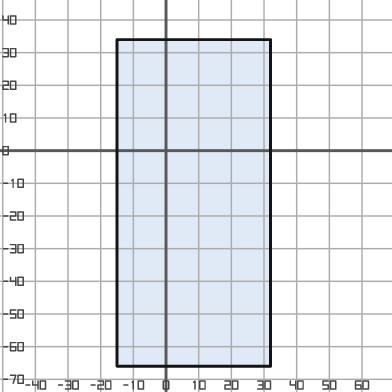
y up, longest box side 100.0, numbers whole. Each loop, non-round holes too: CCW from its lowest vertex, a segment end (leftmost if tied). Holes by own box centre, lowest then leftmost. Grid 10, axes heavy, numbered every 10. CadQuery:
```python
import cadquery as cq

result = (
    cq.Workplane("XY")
    .moveTo(-15.0, -66.0)
    .lineTo(32.0, -66.0)
    .lineTo(32.0, 34.0)
    .lineTo(-15.0, 34.0)
    .close()
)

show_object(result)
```